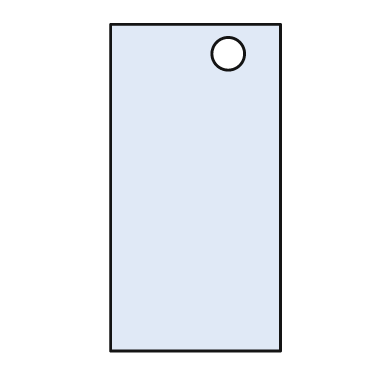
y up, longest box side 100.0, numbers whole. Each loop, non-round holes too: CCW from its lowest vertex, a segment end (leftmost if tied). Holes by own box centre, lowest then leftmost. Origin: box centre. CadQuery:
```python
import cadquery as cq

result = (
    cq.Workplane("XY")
    .moveTo(-26.0, -50.0)
    .lineTo(26.0, -50.0)
    .lineTo(26.0, 50.0)
    .lineTo(-26.0, 50.0)
    .close()
    .moveTo(10.0, 41.0)
    .circle(5.0)
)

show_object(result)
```